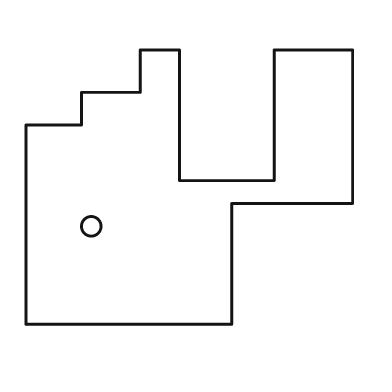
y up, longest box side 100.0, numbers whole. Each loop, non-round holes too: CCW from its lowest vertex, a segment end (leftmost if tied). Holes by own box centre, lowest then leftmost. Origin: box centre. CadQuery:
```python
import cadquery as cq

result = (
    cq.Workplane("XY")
    .moveTo(-50.0, -42.0)
    .lineTo(13.0, -42.0)
    .lineTo(13.0, -5.0)
    .lineTo(50.0, -5.0)
    .lineTo(50.0, 42.0)
    .lineTo(26.0, 42.0)
    .lineTo(26.0, 2.0)
    .lineTo(-3.0, 2.0)
    .lineTo(-3.0, 42.0)
    .lineTo(-15.0, 42.0)
    .lineTo(-15.0, 29.0)
    .lineTo(-33.0, 29.0)
    .lineTo(-33.0, 19.0)
    .lineTo(-50.0, 19.0)
    .close()
    .moveTo(-30.0, -12.0)
    .circle(3.0)
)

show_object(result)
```